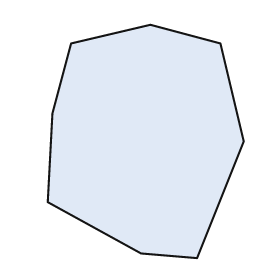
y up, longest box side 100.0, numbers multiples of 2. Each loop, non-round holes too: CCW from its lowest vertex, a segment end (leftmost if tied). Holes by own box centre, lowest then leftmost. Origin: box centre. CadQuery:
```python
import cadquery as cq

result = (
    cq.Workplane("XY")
    .moveTo(22.0, -50.0)
    .lineTo(42.0, 0.0)
    .lineTo(32.0, 42.0)
    .lineTo(2.0, 50.0)
    .lineTo(-32.0, 42.0)
    .lineTo(-40.0, 12.0)
    .lineTo(-42.0, -26.0)
    .lineTo(-2.0, -48.0)
    .close()
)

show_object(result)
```